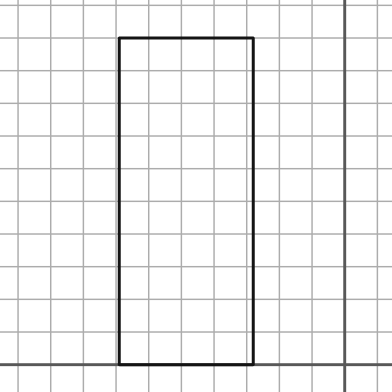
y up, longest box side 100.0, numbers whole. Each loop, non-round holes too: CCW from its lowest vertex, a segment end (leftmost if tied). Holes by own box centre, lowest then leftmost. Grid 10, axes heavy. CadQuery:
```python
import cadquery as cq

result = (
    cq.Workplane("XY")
    .moveTo(-69.0, 0.0)
    .lineTo(-28.0, 0.0)
    .lineTo(-28.0, 100.0)
    .lineTo(-69.0, 100.0)
    .close()
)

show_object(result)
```